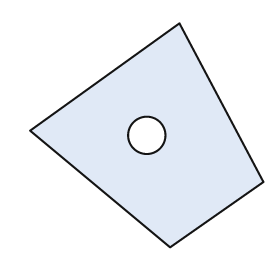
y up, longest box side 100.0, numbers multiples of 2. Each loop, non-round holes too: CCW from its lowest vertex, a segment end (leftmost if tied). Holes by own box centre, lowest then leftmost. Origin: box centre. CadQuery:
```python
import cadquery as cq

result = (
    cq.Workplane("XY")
    .moveTo(10.0, -48.0)
    .lineTo(50.0, -20.0)
    .lineTo(14.0, 48.0)
    .lineTo(-50.0, 2.0)
    .close()
    .moveTo(0.0, 0.0)
    .circle(8.0)
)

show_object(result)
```